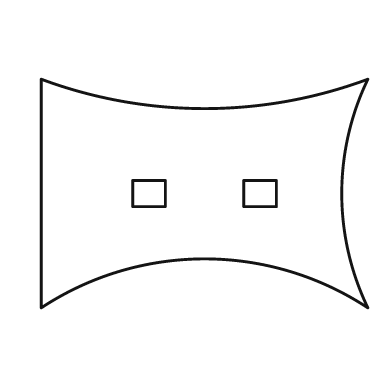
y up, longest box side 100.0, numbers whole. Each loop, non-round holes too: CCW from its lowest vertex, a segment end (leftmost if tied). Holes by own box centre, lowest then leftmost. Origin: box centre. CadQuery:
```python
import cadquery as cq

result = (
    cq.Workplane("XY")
    .moveTo(-50.0, -35.0)
    .threePointArc((0.0, -20.0), (50.0, -35.0))
    .threePointArc((42.0, 0.0), (50.0, 35.0))
    .threePointArc((0.0, 26.0), (-50.0, 35.0))
    .close()
    .moveTo(-22.0, -4.0)
    .lineTo(-12.0, -4.0)
    .lineTo(-12.0, 4.0)
    .lineTo(-22.0, 4.0)
    .close()
    .moveTo(12.0, -4.0)
    .lineTo(22.0, -4.0)
    .lineTo(22.0, 4.0)
    .lineTo(12.0, 4.0)
    .close()
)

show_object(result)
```